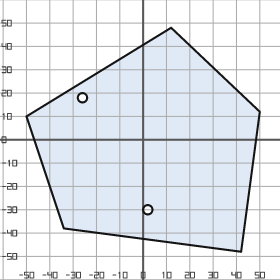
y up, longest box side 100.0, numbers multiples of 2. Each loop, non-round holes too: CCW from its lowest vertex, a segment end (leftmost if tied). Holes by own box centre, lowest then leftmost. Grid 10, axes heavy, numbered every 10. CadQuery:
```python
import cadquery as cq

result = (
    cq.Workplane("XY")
    .moveTo(42.0, -48.0)
    .lineTo(50.0, 12.0)
    .lineTo(12.0, 48.0)
    .lineTo(-50.0, 10.0)
    .lineTo(-34.0, -38.0)
    .close()
    .moveTo(2.0, -30.0)
    .circle(2.0)
    .moveTo(-26.0, 18.0)
    .circle(2.0)
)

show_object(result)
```